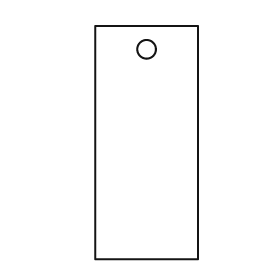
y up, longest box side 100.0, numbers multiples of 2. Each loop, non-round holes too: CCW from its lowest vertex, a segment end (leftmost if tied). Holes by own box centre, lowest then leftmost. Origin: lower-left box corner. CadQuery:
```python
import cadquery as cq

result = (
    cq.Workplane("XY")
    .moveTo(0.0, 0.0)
    .lineTo(44.0, 0.0)
    .lineTo(44.0, 100.0)
    .lineTo(0.0, 100.0)
    .close()
    .moveTo(22.0, 90.0)
    .circle(4.0)
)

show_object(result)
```